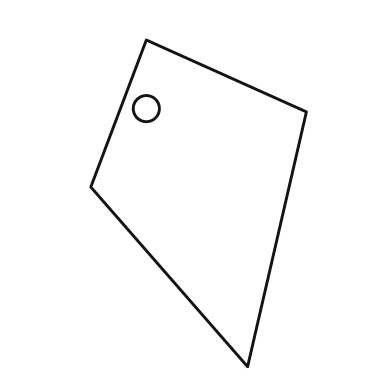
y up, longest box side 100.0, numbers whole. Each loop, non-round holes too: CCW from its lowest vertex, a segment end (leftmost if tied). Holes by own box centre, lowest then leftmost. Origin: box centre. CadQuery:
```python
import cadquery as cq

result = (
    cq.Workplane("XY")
    .moveTo(15.0, -50.0)
    .lineTo(33.0, 28.0)
    .lineTo(-16.0, 50.0)
    .lineTo(-33.0, 5.0)
    .close()
    .moveTo(-16.0, 29.0)
    .circle(4.0)
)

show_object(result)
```